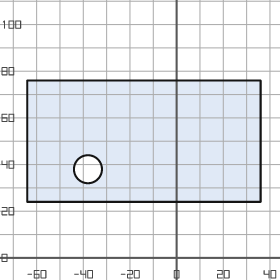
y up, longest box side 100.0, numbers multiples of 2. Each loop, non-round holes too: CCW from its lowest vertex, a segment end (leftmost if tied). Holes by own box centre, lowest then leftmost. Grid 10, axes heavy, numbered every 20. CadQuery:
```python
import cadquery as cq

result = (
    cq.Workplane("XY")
    .moveTo(-64.0, 24.0)
    .lineTo(36.0, 24.0)
    .lineTo(36.0, 76.0)
    .lineTo(-64.0, 76.0)
    .close()
    .moveTo(-38.0, 38.0)
    .circle(6.0)
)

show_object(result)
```